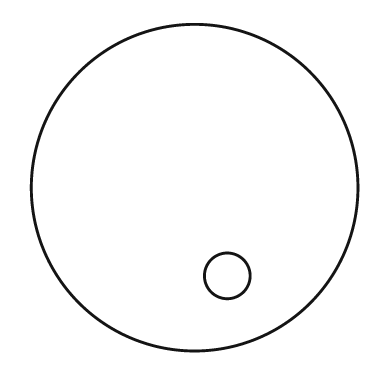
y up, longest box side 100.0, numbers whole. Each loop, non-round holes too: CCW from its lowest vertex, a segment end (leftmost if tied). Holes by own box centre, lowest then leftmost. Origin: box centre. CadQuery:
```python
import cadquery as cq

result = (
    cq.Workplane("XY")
    .moveTo(0.0, 0.0)
    .circle(50.0)
    .moveTo(10.0, -27.0)
    .circle(7.0)
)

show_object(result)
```